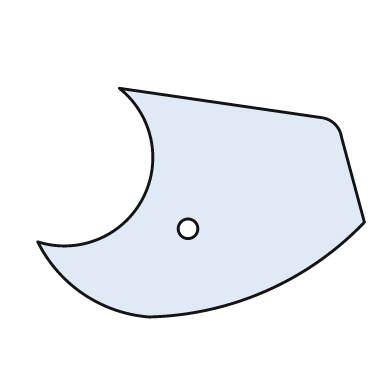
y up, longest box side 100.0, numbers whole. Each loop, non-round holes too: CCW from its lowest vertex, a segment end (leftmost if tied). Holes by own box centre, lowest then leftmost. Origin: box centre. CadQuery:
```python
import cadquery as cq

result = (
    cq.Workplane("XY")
    .moveTo(-16.0, -35.0)
    .threePointArc((20.0, -27.0), (50.0, -6.0))
    .lineTo(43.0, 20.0)
    .threePointArc((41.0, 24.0), (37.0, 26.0))
    .lineTo(-25.0, 35.0)
    .threePointArc((-18.0, 1.0), (-50.0, -12.0))
    .threePointArc((-36.0, -28.0), (-16.0, -35.0))
    .close()
    .moveTo(-4.0, -8.0)
    .circle(3.0)
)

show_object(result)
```